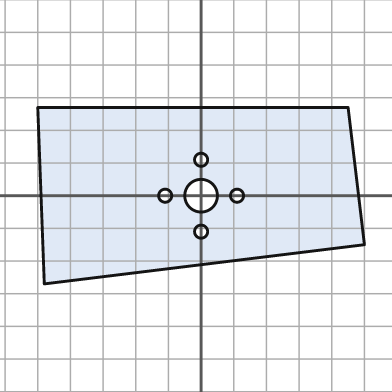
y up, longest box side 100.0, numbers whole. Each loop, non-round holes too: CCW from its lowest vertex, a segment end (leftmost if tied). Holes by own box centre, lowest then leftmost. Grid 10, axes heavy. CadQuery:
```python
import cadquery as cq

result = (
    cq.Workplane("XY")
    .moveTo(-48.0, -27.0)
    .lineTo(50.0, -15.0)
    .lineTo(45.0, 27.0)
    .lineTo(-50.0, 27.0)
    .close()
    .moveTo(0.0, -11.0)
    .circle(2.0)
    .moveTo(-11.0, 0.0)
    .circle(2.0)
    .moveTo(0.0, 0.0)
    .circle(5.0)
    .moveTo(11.0, 0.0)
    .circle(2.0)
    .moveTo(0.0, 11.0)
    .circle(2.0)
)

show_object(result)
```